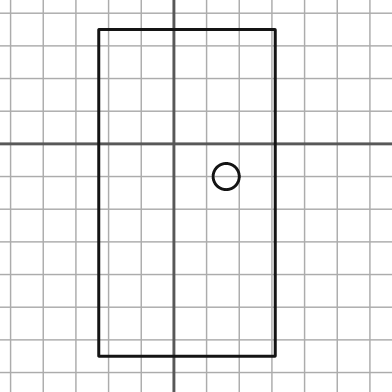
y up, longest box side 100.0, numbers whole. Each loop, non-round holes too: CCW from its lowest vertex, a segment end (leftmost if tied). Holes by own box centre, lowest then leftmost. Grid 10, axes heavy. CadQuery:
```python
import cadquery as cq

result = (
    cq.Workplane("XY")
    .moveTo(-23.0, -65.0)
    .lineTo(31.0, -65.0)
    .lineTo(31.0, 35.0)
    .lineTo(-23.0, 35.0)
    .close()
    .moveTo(16.0, -10.0)
    .circle(4.0)
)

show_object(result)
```